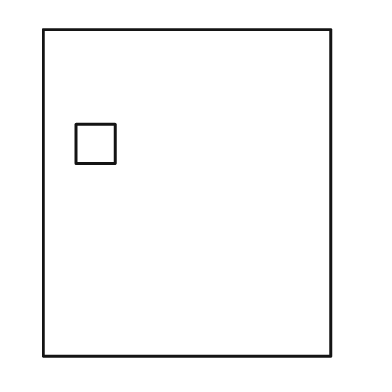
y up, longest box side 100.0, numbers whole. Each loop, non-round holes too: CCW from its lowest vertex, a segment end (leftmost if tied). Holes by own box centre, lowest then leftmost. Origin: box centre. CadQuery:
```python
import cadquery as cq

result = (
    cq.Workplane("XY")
    .moveTo(-44.0, -50.0)
    .lineTo(44.0, -50.0)
    .lineTo(44.0, 50.0)
    .lineTo(-44.0, 50.0)
    .close()
    .moveTo(-34.0, 9.0)
    .lineTo(-22.0, 9.0)
    .lineTo(-22.0, 21.0)
    .lineTo(-34.0, 21.0)
    .close()
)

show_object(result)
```